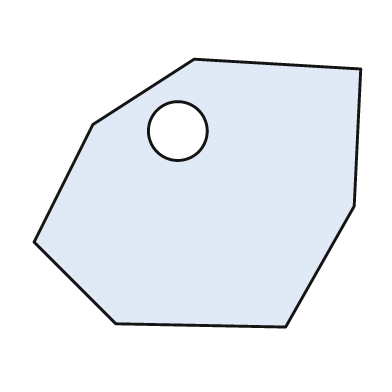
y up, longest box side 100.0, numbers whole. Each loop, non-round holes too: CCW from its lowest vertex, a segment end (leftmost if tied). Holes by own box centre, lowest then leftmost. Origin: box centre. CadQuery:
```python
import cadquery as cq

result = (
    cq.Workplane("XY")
    .moveTo(27.0, -41.0)
    .lineTo(48.0, -4.0)
    .lineTo(50.0, 38.0)
    .lineTo(-1.0, 41.0)
    .lineTo(-32.0, 21.0)
    .lineTo(-50.0, -15.0)
    .lineTo(-25.0, -40.0)
    .close()
    .moveTo(-6.0, 19.0)
    .circle(9.0)
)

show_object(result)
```